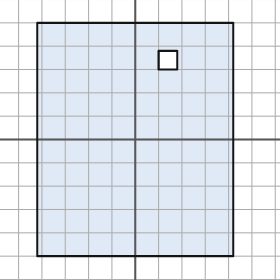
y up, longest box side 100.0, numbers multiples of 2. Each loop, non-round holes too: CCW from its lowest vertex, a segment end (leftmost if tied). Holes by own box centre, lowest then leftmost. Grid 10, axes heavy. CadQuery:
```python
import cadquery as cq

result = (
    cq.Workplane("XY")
    .moveTo(-42.0, -50.0)
    .lineTo(42.0, -50.0)
    .lineTo(42.0, 50.0)
    .lineTo(-42.0, 50.0)
    .close()
    .moveTo(10.0, 30.0)
    .lineTo(18.0, 30.0)
    .lineTo(18.0, 38.0)
    .lineTo(10.0, 38.0)
    .close()
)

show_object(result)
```